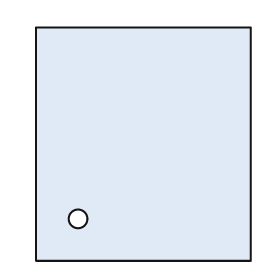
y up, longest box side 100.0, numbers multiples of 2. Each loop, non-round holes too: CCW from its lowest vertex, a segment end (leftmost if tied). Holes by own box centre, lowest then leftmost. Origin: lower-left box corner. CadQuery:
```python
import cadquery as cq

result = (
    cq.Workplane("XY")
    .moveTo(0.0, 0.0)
    .lineTo(92.0, 0.0)
    .lineTo(92.0, 100.0)
    .lineTo(0.0, 100.0)
    .close()
    .moveTo(18.0, 18.0)
    .circle(4.0)
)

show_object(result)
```